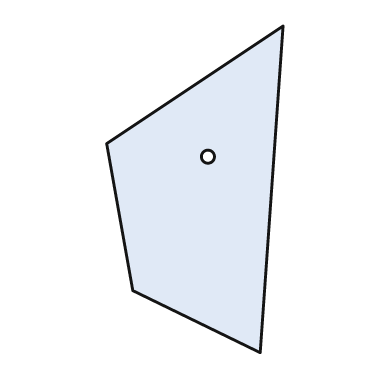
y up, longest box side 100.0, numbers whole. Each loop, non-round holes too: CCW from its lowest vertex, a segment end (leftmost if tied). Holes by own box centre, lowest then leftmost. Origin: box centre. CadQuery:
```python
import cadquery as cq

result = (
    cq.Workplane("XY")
    .moveTo(20.0, -50.0)
    .lineTo(27.0, 50.0)
    .lineTo(-27.0, 14.0)
    .lineTo(-19.0, -31.0)
    .close()
    .moveTo(4.0, 10.0)
    .circle(2.0)
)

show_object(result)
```